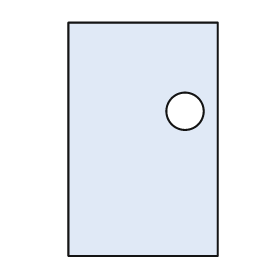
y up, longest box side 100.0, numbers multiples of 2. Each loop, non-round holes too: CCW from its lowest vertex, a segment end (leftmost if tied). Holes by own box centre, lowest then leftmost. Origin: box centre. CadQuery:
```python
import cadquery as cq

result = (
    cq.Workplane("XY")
    .moveTo(-32.0, -50.0)
    .lineTo(32.0, -50.0)
    .lineTo(32.0, 50.0)
    .lineTo(-32.0, 50.0)
    .close()
    .moveTo(18.0, 12.0)
    .circle(8.0)
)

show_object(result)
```